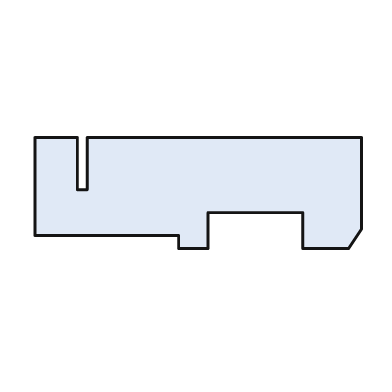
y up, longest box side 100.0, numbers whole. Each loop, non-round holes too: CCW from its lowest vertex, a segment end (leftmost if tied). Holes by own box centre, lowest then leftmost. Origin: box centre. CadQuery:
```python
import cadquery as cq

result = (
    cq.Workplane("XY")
    .moveTo(-6.0, -17.0)
    .lineTo(3.0, -17.0)
    .lineTo(3.0, -6.0)
    .lineTo(32.0, -6.0)
    .lineTo(32.0, -17.0)
    .lineTo(46.0, -17.0)
    .lineTo(50.0, -11.0)
    .lineTo(50.0, 17.0)
    .lineTo(-34.0, 17.0)
    .lineTo(-34.0, 1.0)
    .lineTo(-37.0, 1.0)
    .lineTo(-37.0, 17.0)
    .lineTo(-50.0, 17.0)
    .lineTo(-50.0, -13.0)
    .lineTo(-6.0, -13.0)
    .close()
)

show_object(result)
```